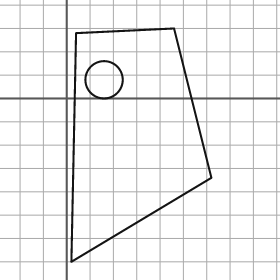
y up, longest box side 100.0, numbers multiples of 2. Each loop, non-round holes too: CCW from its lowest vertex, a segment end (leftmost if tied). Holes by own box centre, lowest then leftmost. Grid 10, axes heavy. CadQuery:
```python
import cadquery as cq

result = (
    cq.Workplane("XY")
    .moveTo(2.0, -70.0)
    .lineTo(62.0, -34.0)
    .lineTo(46.0, 30.0)
    .lineTo(4.0, 28.0)
    .close()
    .moveTo(16.0, 8.0)
    .circle(8.0)
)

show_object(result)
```